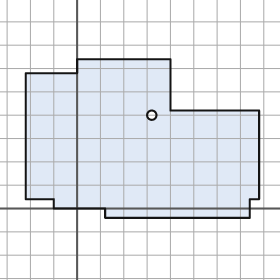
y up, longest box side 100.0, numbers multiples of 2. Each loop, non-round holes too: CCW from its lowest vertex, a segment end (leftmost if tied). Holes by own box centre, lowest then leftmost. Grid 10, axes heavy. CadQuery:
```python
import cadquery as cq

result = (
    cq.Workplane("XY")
    .moveTo(12.0, -4.0)
    .lineTo(74.0, -4.0)
    .lineTo(74.0, 4.0)
    .lineTo(78.0, 4.0)
    .lineTo(78.0, 42.0)
    .lineTo(40.0, 42.0)
    .lineTo(40.0, 64.0)
    .lineTo(0.0, 64.0)
    .lineTo(0.0, 58.0)
    .lineTo(-22.0, 58.0)
    .lineTo(-22.0, 4.0)
    .lineTo(-10.0, 4.0)
    .lineTo(-10.0, 0.0)
    .lineTo(12.0, 0.0)
    .close()
    .moveTo(32.0, 40.0)
    .circle(2.0)
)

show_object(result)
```